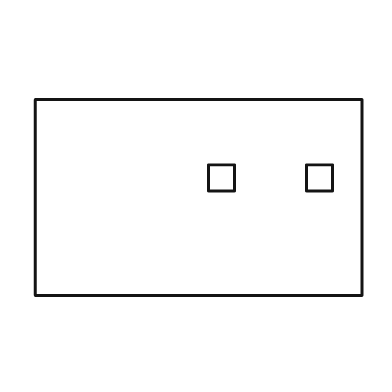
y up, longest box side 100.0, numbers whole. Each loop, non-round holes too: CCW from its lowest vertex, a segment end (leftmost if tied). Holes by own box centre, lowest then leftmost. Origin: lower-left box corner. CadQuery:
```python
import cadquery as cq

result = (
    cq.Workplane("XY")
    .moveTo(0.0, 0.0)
    .lineTo(100.0, 0.0)
    .lineTo(100.0, 60.0)
    .lineTo(0.0, 60.0)
    .close()
    .moveTo(53.0, 32.0)
    .lineTo(61.0, 32.0)
    .lineTo(61.0, 40.0)
    .lineTo(53.0, 40.0)
    .close()
    .moveTo(83.0, 32.0)
    .lineTo(91.0, 32.0)
    .lineTo(91.0, 40.0)
    .lineTo(83.0, 40.0)
    .close()
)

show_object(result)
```